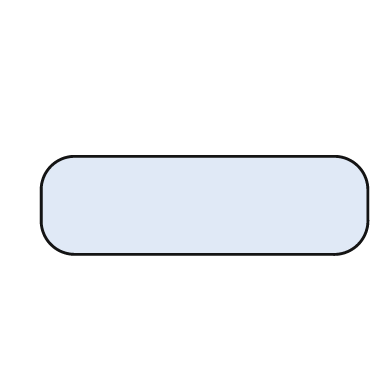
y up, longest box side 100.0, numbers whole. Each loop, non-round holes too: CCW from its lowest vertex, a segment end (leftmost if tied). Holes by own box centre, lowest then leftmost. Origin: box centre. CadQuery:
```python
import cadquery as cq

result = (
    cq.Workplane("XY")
    .moveTo(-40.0, -15.0)
    .lineTo(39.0, -15.0)
    .threePointArc((47.0, -12.0), (50.0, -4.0))
    .lineTo(50.0, 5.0)
    .threePointArc((47.0, 12.0), (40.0, 15.0))
    .lineTo(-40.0, 15.0)
    .threePointArc((-47.0, 12.0), (-50.0, 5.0))
    .lineTo(-50.0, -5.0)
    .threePointArc((-47.0, -12.0), (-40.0, -15.0))
    .close()
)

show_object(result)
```